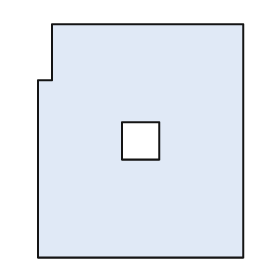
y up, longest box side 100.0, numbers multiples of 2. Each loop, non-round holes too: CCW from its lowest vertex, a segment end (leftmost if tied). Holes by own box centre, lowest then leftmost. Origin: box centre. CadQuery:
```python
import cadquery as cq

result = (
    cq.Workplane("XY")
    .moveTo(-44.0, -50.0)
    .lineTo(44.0, -50.0)
    .lineTo(44.0, 50.0)
    .lineTo(-38.0, 50.0)
    .lineTo(-38.0, 26.0)
    .lineTo(-44.0, 26.0)
    .close()
    .moveTo(-8.0, -8.0)
    .lineTo(8.0, -8.0)
    .lineTo(8.0, 8.0)
    .lineTo(-8.0, 8.0)
    .close()
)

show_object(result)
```